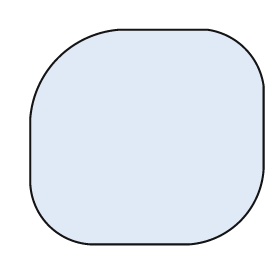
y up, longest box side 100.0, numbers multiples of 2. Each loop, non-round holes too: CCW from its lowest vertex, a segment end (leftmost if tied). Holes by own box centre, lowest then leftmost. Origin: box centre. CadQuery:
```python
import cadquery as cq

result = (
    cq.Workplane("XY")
    .moveTo(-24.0, -46.0)
    .lineTo(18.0, -46.0)
    .threePointArc((40.0, -36.0), (50.0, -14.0))
    .lineTo(50.0, 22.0)
    .threePointArc((42.0, 38.0), (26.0, 46.0))
    .lineTo(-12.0, 46.0)
    .threePointArc((-38.0, 34.0), (-50.0, 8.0))
    .lineTo(-50.0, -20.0)
    .threePointArc((-42.0, -38.0), (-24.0, -46.0))
    .close()
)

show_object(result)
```